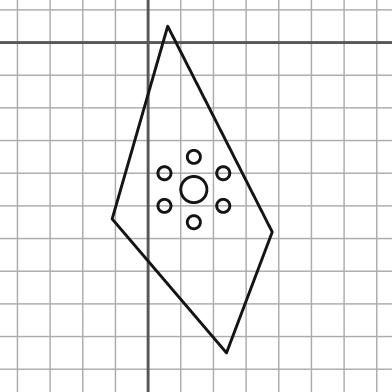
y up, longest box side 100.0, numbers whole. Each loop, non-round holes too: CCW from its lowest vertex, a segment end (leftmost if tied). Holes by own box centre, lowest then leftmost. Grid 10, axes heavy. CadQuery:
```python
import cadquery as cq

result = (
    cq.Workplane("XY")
    .moveTo(24.0, -95.0)
    .lineTo(38.0, -58.0)
    .lineTo(6.0, 5.0)
    .lineTo(-11.0, -54.0)
    .close()
    .moveTo(14.0, -55.0)
    .circle(2.0)
    .moveTo(5.0, -50.0)
    .circle(2.0)
    .moveTo(23.0, -50.0)
    .circle(2.0)
    .moveTo(14.0, -45.0)
    .circle(4.0)
    .moveTo(5.0, -40.0)
    .circle(2.0)
    .moveTo(23.0, -40.0)
    .circle(2.0)
    .moveTo(14.0, -35.0)
    .circle(2.0)
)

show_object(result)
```